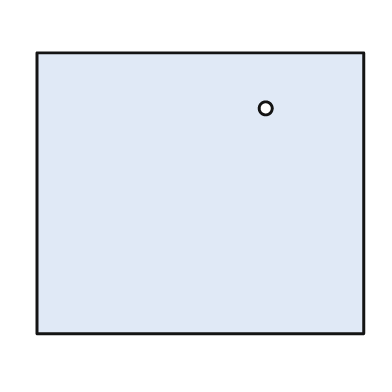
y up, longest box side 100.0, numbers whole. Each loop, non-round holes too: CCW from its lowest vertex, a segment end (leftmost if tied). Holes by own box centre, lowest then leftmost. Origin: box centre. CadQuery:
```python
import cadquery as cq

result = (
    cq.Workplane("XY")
    .moveTo(-50.0, -43.0)
    .lineTo(50.0, -43.0)
    .lineTo(50.0, 43.0)
    .lineTo(-50.0, 43.0)
    .close()
    .moveTo(20.0, 26.0)
    .circle(2.0)
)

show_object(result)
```